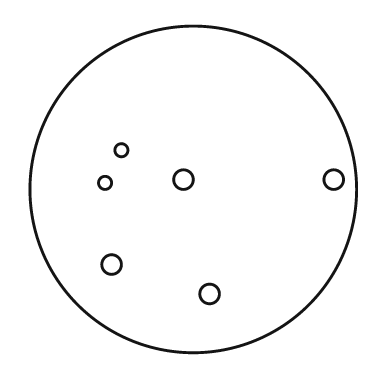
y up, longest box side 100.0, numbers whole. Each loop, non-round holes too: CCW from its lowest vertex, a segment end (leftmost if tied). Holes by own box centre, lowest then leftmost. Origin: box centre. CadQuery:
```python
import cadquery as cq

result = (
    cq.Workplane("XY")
    .moveTo(0.0, 0.0)
    .circle(50.0)
    .moveTo(5.0, -32.0)
    .circle(3.0)
    .moveTo(-25.0, -23.0)
    .circle(3.0)
    .moveTo(-27.0, 2.0)
    .circle(2.0)
    .moveTo(-3.0, 3.0)
    .circle(3.0)
    .moveTo(43.0, 3.0)
    .circle(3.0)
    .moveTo(-22.0, 12.0)
    .circle(2.0)
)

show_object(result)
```